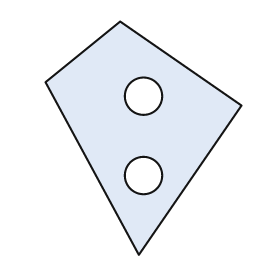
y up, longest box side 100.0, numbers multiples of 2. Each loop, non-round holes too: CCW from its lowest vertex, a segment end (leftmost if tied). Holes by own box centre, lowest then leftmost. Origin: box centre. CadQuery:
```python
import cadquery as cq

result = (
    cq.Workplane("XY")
    .moveTo(-2.0, -50.0)
    .lineTo(42.0, 14.0)
    .lineTo(-10.0, 50.0)
    .lineTo(-42.0, 24.0)
    .close()
    .moveTo(0.0, -16.0)
    .circle(8.0)
    .moveTo(0.0, 18.0)
    .circle(8.0)
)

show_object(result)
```